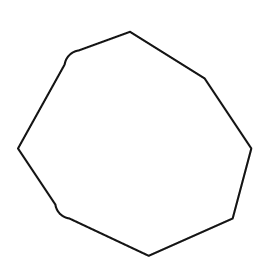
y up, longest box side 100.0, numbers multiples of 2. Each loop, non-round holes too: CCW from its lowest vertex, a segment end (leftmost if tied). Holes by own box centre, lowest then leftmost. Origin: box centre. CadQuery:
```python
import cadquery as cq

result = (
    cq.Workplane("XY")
    .moveTo(6.0, -48.0)
    .lineTo(42.0, -32.0)
    .lineTo(50.0, -2.0)
    .lineTo(30.0, 28.0)
    .lineTo(-2.0, 48.0)
    .lineTo(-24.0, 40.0)
    .threePointArc((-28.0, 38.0), (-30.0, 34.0))
    .lineTo(-50.0, -2.0)
    .lineTo(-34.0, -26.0)
    .threePointArc((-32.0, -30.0), (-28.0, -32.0))
    .close()
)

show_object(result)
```